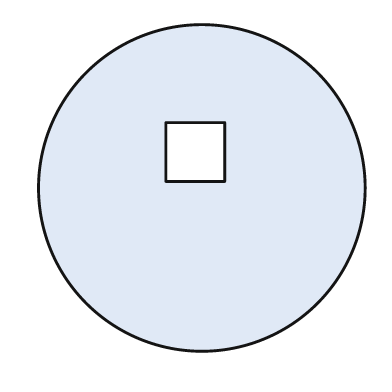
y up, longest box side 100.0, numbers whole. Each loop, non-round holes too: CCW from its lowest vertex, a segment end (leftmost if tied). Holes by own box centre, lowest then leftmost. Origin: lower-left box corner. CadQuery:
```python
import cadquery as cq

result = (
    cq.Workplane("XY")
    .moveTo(50.0, 50.0)
    .circle(50.0)
    .moveTo(39.0, 52.0)
    .lineTo(57.0, 52.0)
    .lineTo(57.0, 70.0)
    .lineTo(39.0, 70.0)
    .close()
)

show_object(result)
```